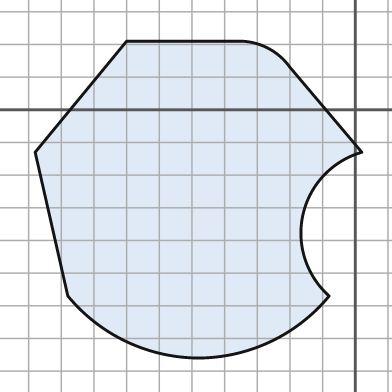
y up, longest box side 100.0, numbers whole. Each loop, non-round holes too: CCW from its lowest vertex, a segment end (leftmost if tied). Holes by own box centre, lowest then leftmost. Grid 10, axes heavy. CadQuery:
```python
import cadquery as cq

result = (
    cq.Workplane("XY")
    .moveTo(-48.0, -76.0)
    .threePointArc((-26.0, -71.0), (-8.0, -57.0))
    .threePointArc((-16.0, -32.0), (2.0, -13.0))
    .lineTo(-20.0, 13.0)
    .threePointArc((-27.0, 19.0), (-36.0, 21.0))
    .lineTo(-70.0, 21.0)
    .lineTo(-98.0, -13.0)
    .lineTo(-88.0, -57.0)
    .threePointArc((-70.0, -71.0), (-48.0, -76.0))
    .close()
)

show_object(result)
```